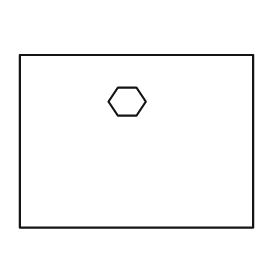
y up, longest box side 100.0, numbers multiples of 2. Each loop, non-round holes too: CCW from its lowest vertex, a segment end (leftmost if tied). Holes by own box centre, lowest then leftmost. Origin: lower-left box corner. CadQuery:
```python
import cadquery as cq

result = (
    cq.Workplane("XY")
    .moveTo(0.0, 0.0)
    .lineTo(100.0, 0.0)
    .lineTo(100.0, 74.0)
    .lineTo(0.0, 74.0)
    .close()
    .moveTo(42.0, 48.0)
    .lineTo(50.0, 48.0)
    .lineTo(54.0, 54.0)
    .lineTo(50.0, 60.0)
    .lineTo(42.0, 60.0)
    .lineTo(38.0, 54.0)
    .close()
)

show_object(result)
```